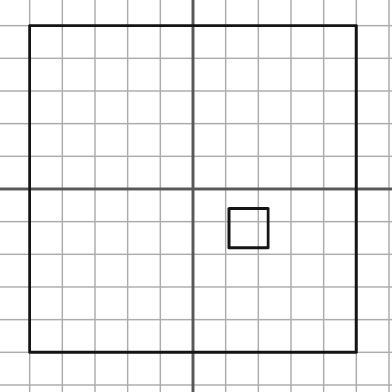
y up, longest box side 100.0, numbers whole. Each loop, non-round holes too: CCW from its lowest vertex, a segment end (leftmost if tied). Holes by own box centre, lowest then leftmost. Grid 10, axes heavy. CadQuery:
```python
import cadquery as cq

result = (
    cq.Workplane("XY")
    .moveTo(-50.0, -50.0)
    .lineTo(50.0, -50.0)
    .lineTo(50.0, 50.0)
    .lineTo(-50.0, 50.0)
    .close()
    .moveTo(11.0, -18.0)
    .lineTo(23.0, -18.0)
    .lineTo(23.0, -6.0)
    .lineTo(11.0, -6.0)
    .close()
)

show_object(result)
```